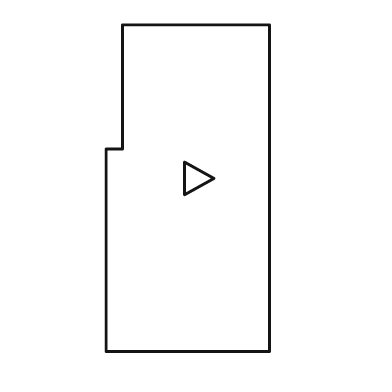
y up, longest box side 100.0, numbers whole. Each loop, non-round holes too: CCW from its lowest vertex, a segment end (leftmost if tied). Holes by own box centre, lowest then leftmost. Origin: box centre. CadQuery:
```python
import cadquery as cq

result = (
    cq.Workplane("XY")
    .moveTo(-25.0, -50.0)
    .lineTo(25.0, -50.0)
    .lineTo(25.0, 50.0)
    .lineTo(-20.0, 50.0)
    .lineTo(-20.0, 12.0)
    .lineTo(-25.0, 12.0)
    .close()
    .moveTo(-1.0, -2.0)
    .lineTo(8.0, 3.0)
    .lineTo(-1.0, 8.0)
    .close()
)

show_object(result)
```